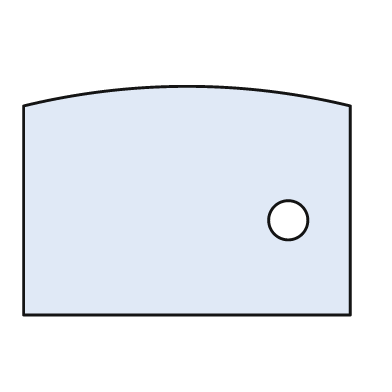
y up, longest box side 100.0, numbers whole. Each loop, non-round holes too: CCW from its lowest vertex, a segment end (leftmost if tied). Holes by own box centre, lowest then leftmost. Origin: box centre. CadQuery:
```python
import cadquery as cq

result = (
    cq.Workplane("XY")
    .moveTo(-50.0, -35.0)
    .lineTo(50.0, -35.0)
    .lineTo(50.0, 29.0)
    .threePointArc((0.0, 35.0), (-50.0, 29.0))
    .close()
    .moveTo(31.0, -6.0)
    .circle(6.0)
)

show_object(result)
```